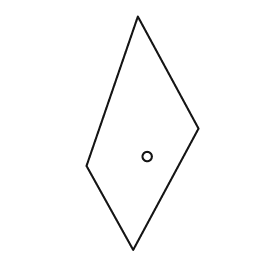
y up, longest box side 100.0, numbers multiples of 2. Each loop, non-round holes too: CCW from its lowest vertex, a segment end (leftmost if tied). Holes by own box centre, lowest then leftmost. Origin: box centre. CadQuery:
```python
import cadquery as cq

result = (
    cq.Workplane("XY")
    .moveTo(-4.0, -50.0)
    .lineTo(24.0, 2.0)
    .lineTo(-2.0, 50.0)
    .lineTo(-24.0, -14.0)
    .close()
    .moveTo(2.0, -10.0)
    .circle(2.0)
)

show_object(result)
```